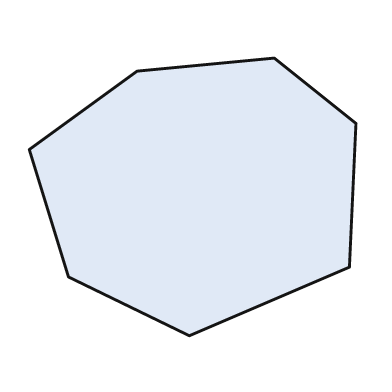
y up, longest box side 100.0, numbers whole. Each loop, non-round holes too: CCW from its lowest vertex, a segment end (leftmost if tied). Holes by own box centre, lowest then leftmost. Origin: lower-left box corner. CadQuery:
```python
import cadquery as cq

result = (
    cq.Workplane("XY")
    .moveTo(49.0, 0.0)
    .lineTo(98.0, 21.0)
    .lineTo(100.0, 65.0)
    .lineTo(75.0, 85.0)
    .lineTo(33.0, 81.0)
    .lineTo(0.0, 57.0)
    .lineTo(12.0, 18.0)
    .close()
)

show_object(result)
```